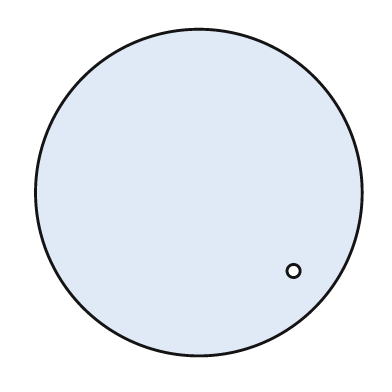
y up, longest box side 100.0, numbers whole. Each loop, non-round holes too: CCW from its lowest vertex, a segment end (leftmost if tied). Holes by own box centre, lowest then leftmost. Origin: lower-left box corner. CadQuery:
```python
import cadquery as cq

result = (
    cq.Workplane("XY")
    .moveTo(50.0, 50.0)
    .circle(50.0)
    .moveTo(79.0, 26.0)
    .circle(2.0)
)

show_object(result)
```